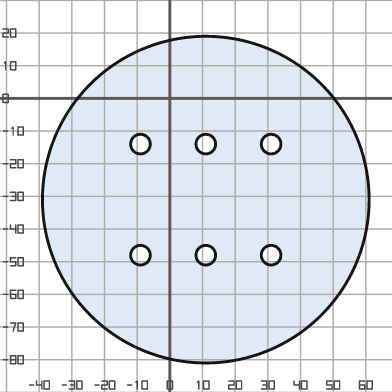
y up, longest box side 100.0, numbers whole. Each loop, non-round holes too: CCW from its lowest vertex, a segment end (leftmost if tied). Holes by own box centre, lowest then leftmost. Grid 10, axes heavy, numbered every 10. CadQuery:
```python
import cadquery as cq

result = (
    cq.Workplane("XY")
    .moveTo(11.0, -31.0)
    .circle(50.0)
    .moveTo(-9.0, -48.0)
    .circle(3.0)
    .moveTo(11.0, -48.0)
    .circle(3.0)
    .moveTo(31.0, -48.0)
    .circle(3.0)
    .moveTo(-9.0, -14.0)
    .circle(3.0)
    .moveTo(11.0, -14.0)
    .circle(3.0)
    .moveTo(31.0, -14.0)
    .circle(3.0)
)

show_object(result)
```